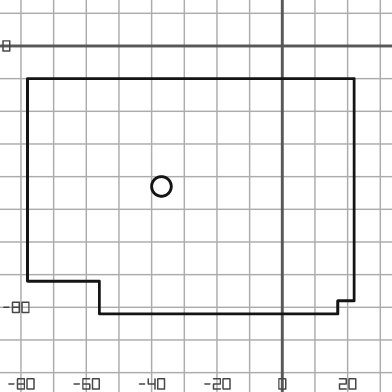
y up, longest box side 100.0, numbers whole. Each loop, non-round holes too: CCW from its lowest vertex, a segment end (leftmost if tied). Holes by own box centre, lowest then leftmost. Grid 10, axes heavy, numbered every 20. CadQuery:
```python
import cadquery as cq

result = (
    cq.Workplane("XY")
    .moveTo(-56.0, -82.0)
    .lineTo(17.0, -82.0)
    .lineTo(17.0, -78.0)
    .lineTo(22.0, -78.0)
    .lineTo(22.0, -10.0)
    .lineTo(-78.0, -10.0)
    .lineTo(-78.0, -72.0)
    .lineTo(-56.0, -72.0)
    .close()
    .moveTo(-37.0, -43.0)
    .circle(3.0)
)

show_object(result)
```